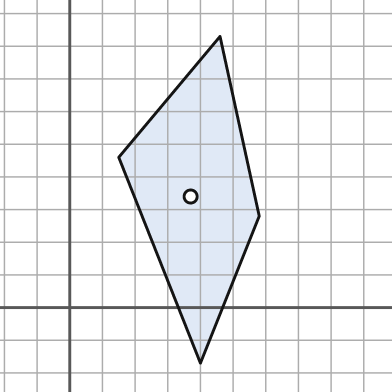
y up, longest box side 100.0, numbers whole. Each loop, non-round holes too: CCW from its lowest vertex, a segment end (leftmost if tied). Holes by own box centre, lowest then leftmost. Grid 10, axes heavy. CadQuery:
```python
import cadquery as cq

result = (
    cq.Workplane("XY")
    .moveTo(40.0, -17.0)
    .lineTo(58.0, 28.0)
    .lineTo(46.0, 83.0)
    .lineTo(15.0, 46.0)
    .close()
    .moveTo(37.0, 34.0)
    .circle(2.0)
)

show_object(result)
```